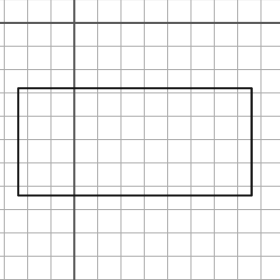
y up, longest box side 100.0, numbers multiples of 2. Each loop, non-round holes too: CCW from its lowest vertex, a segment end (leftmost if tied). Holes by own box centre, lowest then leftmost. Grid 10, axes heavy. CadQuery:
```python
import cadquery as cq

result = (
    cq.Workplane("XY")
    .moveTo(-24.0, -74.0)
    .lineTo(76.0, -74.0)
    .lineTo(76.0, -28.0)
    .lineTo(-24.0, -28.0)
    .close()
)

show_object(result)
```